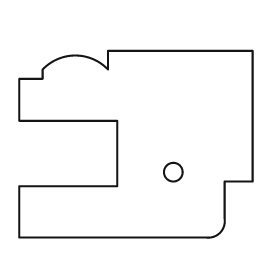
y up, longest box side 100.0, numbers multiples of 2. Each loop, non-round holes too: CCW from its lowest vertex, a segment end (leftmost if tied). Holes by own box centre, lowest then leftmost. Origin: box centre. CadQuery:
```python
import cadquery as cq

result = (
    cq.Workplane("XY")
    .moveTo(-50.0, -40.0)
    .lineTo(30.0, -40.0)
    .threePointArc((36.0, -38.0), (38.0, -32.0))
    .lineTo(38.0, -16.0)
    .lineTo(50.0, -16.0)
    .lineTo(50.0, 40.0)
    .lineTo(-12.0, 40.0)
    .lineTo(-12.0, 32.0)
    .threePointArc((-26.0, 38.0), (-40.0, 32.0))
    .lineTo(-40.0, 28.0)
    .lineTo(-50.0, 28.0)
    .lineTo(-50.0, 10.0)
    .lineTo(-8.0, 10.0)
    .lineTo(-8.0, -18.0)
    .lineTo(-50.0, -18.0)
    .close()
    .moveTo(16.0, -12.0)
    .circle(4.0)
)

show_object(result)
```